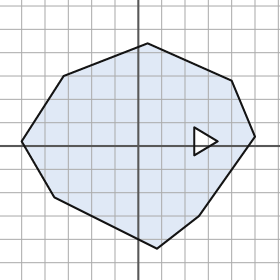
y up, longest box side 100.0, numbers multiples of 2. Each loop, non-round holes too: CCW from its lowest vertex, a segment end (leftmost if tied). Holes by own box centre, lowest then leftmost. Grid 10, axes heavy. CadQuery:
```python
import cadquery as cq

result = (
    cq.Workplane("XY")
    .moveTo(8.0, -44.0)
    .lineTo(26.0, -30.0)
    .lineTo(50.0, 4.0)
    .lineTo(40.0, 28.0)
    .lineTo(4.0, 44.0)
    .lineTo(-32.0, 30.0)
    .lineTo(-50.0, 2.0)
    .lineTo(-36.0, -22.0)
    .close()
    .moveTo(24.0, -4.0)
    .lineTo(34.0, 2.0)
    .lineTo(24.0, 8.0)
    .close()
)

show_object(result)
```